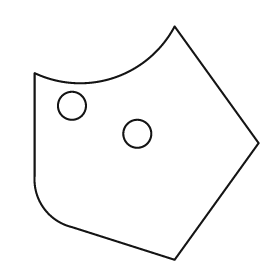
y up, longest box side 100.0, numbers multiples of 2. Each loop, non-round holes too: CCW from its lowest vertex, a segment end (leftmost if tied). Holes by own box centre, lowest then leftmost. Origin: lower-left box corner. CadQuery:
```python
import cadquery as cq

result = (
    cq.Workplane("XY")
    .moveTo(60.0, 0.0)
    .lineTo(96.0, 50.0)
    .lineTo(60.0, 100.0)
    .threePointArc((34.0, 78.0), (0.0, 80.0))
    .lineTo(0.0, 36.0)
    .threePointArc((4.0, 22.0), (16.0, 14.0))
    .close()
    .moveTo(44.0, 54.0)
    .circle(6.0)
    .moveTo(16.0, 66.0)
    .circle(6.0)
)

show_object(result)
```